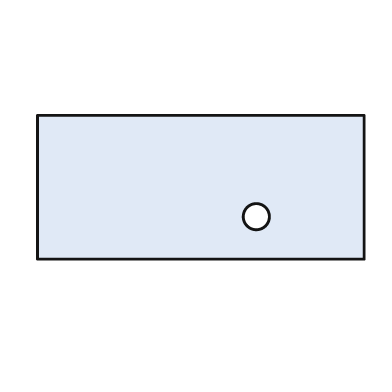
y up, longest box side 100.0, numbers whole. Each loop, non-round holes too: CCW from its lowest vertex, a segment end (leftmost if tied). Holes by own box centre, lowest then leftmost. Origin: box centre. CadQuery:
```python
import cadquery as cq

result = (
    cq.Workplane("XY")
    .moveTo(-50.0, -22.0)
    .lineTo(50.0, -22.0)
    .lineTo(50.0, 22.0)
    .lineTo(-50.0, 22.0)
    .close()
    .moveTo(17.0, -9.0)
    .circle(4.0)
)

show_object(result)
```